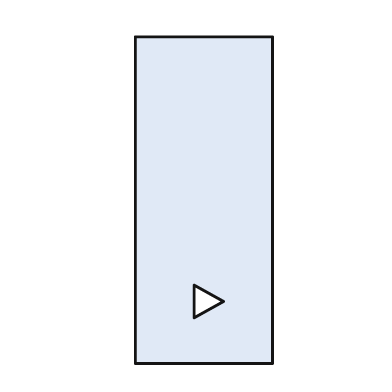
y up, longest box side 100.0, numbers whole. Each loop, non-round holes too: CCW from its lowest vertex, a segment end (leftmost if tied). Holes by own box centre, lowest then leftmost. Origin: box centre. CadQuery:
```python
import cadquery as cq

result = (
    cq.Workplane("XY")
    .moveTo(-21.0, -50.0)
    .lineTo(21.0, -50.0)
    .lineTo(21.0, 50.0)
    .lineTo(-21.0, 50.0)
    .close()
    .moveTo(-3.0, -36.0)
    .lineTo(6.0, -31.0)
    .lineTo(-3.0, -26.0)
    .close()
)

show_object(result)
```